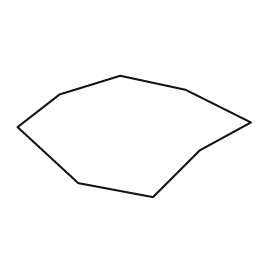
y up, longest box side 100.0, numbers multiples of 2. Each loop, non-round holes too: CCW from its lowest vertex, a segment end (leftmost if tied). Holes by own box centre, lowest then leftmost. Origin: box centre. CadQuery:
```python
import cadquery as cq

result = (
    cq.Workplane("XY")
    .moveTo(8.0, -26.0)
    .lineTo(28.0, -6.0)
    .lineTo(50.0, 6.0)
    .lineTo(22.0, 20.0)
    .lineTo(-6.0, 26.0)
    .lineTo(-32.0, 18.0)
    .lineTo(-50.0, 4.0)
    .lineTo(-24.0, -20.0)
    .close()
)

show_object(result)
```